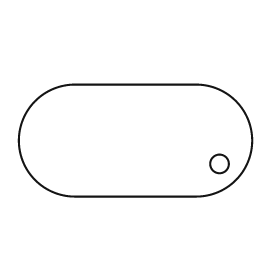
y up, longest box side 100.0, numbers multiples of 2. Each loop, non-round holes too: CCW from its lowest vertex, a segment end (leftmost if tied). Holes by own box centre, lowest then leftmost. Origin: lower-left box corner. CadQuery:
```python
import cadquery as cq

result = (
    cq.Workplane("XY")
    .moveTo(24.0, 0.0)
    .lineTo(76.0, 0.0)
    .threePointArc((100.0, 24.0), (76.0, 48.0))
    .lineTo(24.0, 48.0)
    .threePointArc((0.0, 24.0), (24.0, 0.0))
    .close()
    .moveTo(86.0, 14.0)
    .circle(4.0)
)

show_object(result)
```